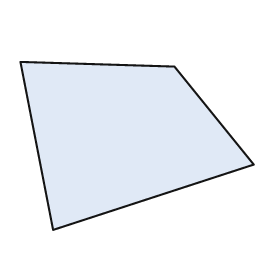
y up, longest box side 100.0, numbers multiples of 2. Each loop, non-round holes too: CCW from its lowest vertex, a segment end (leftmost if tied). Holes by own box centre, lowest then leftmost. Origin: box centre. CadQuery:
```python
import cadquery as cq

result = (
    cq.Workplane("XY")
    .moveTo(-36.0, -36.0)
    .lineTo(50.0, -8.0)
    .lineTo(16.0, 34.0)
    .lineTo(-50.0, 36.0)
    .close()
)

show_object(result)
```